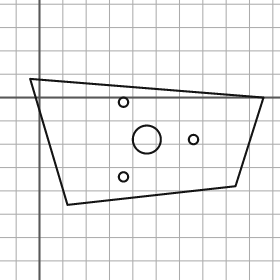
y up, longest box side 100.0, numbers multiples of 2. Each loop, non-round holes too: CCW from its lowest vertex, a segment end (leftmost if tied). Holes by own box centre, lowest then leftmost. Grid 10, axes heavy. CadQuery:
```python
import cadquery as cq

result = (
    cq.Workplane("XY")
    .moveTo(12.0, -46.0)
    .lineTo(84.0, -38.0)
    .lineTo(96.0, 0.0)
    .lineTo(-4.0, 8.0)
    .close()
    .moveTo(36.0, -34.0)
    .circle(2.0)
    .moveTo(46.0, -18.0)
    .circle(6.0)
    .moveTo(66.0, -18.0)
    .circle(2.0)
    .moveTo(36.0, -2.0)
    .circle(2.0)
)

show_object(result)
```